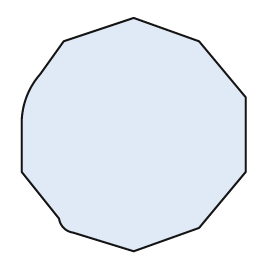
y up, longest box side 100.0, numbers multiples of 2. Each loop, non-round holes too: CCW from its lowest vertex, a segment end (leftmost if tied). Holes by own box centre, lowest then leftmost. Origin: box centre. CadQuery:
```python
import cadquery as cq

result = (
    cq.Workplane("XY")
    .moveTo(0.0, -50.0)
    .lineTo(28.0, -40.0)
    .lineTo(48.0, -16.0)
    .lineTo(48.0, 16.0)
    .lineTo(28.0, 40.0)
    .lineTo(0.0, 50.0)
    .lineTo(-30.0, 40.0)
    .lineTo(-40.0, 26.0)
    .threePointArc((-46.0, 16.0), (-48.0, 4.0))
    .lineTo(-48.0, -16.0)
    .lineTo(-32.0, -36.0)
    .threePointArc((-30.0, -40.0), (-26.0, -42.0))
    .close()
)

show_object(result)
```